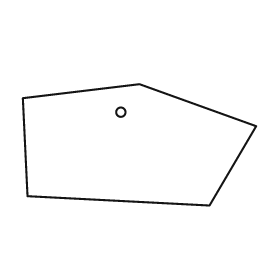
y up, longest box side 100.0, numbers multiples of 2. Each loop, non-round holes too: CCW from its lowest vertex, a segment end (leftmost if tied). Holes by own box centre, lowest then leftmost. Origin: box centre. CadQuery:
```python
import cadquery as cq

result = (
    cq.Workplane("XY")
    .moveTo(30.0, -26.0)
    .lineTo(50.0, 8.0)
    .lineTo(0.0, 26.0)
    .lineTo(-50.0, 20.0)
    .lineTo(-48.0, -22.0)
    .close()
    .moveTo(-8.0, 14.0)
    .circle(2.0)
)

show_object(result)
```